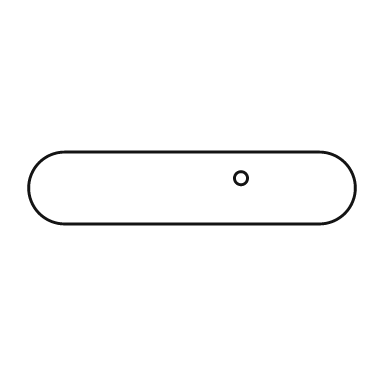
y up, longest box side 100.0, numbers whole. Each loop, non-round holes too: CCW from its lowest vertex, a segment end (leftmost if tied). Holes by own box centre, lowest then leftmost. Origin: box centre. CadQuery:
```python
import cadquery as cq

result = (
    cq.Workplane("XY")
    .moveTo(-39.0, -11.0)
    .lineTo(39.0, -11.0)
    .threePointArc((50.0, 0.0), (39.0, 11.0))
    .lineTo(-39.0, 11.0)
    .threePointArc((-50.0, 0.0), (-39.0, -11.0))
    .close()
    .moveTo(15.0, 3.0)
    .circle(2.0)
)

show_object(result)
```